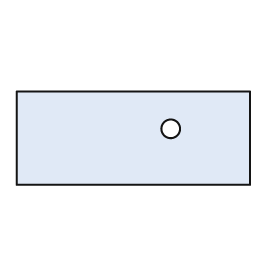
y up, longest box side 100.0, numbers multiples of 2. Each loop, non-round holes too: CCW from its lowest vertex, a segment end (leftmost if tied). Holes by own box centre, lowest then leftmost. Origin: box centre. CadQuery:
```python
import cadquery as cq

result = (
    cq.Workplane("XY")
    .moveTo(-50.0, -20.0)
    .lineTo(50.0, -20.0)
    .lineTo(50.0, 20.0)
    .lineTo(-50.0, 20.0)
    .close()
    .moveTo(16.0, 4.0)
    .circle(4.0)
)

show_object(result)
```